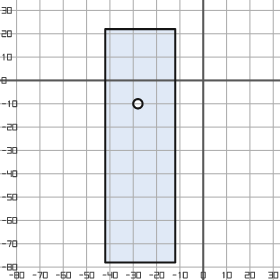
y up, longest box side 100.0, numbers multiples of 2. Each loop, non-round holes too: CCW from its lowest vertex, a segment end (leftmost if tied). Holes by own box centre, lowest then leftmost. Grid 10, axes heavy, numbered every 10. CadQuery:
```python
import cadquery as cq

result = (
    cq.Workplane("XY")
    .moveTo(-42.0, -78.0)
    .lineTo(-12.0, -78.0)
    .lineTo(-12.0, 22.0)
    .lineTo(-42.0, 22.0)
    .close()
    .moveTo(-28.0, -10.0)
    .circle(2.0)
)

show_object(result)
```